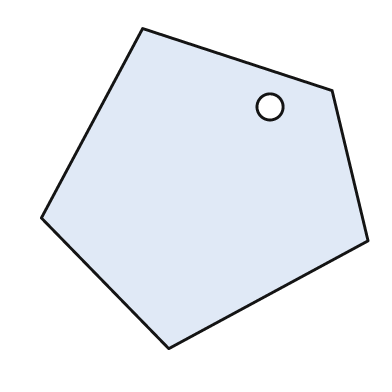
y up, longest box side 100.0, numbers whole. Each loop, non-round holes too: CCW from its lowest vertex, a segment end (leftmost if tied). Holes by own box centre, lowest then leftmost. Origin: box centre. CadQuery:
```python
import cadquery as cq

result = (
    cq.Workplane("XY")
    .moveTo(-11.0, -49.0)
    .lineTo(50.0, -16.0)
    .lineTo(39.0, 30.0)
    .lineTo(-19.0, 49.0)
    .lineTo(-50.0, -9.0)
    .close()
    .moveTo(20.0, 25.0)
    .circle(4.0)
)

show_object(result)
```